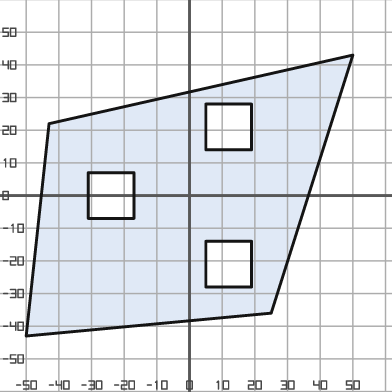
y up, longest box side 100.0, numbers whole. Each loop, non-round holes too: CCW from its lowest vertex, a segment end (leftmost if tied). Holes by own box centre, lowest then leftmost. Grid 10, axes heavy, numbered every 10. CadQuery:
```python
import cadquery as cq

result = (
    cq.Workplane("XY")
    .moveTo(-50.0, -43.0)
    .lineTo(25.0, -36.0)
    .lineTo(50.0, 43.0)
    .lineTo(-43.0, 22.0)
    .close()
    .moveTo(5.0, -28.0)
    .lineTo(19.0, -28.0)
    .lineTo(19.0, -14.0)
    .lineTo(5.0, -14.0)
    .close()
    .moveTo(-31.0, -7.0)
    .lineTo(-17.0, -7.0)
    .lineTo(-17.0, 7.0)
    .lineTo(-31.0, 7.0)
    .close()
    .moveTo(5.0, 14.0)
    .lineTo(19.0, 14.0)
    .lineTo(19.0, 28.0)
    .lineTo(5.0, 28.0)
    .close()
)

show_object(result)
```